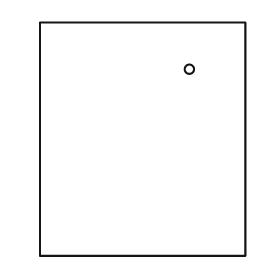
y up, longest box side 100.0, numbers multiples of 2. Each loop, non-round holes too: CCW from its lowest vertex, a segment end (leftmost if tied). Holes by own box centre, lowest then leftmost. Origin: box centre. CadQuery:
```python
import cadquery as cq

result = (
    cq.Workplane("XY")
    .moveTo(-44.0, -50.0)
    .lineTo(44.0, -50.0)
    .lineTo(44.0, 50.0)
    .lineTo(-44.0, 50.0)
    .close()
    .moveTo(20.0, 30.0)
    .circle(2.0)
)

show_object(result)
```